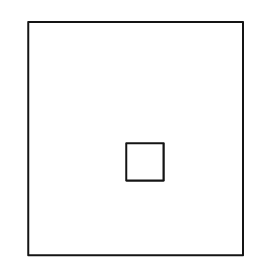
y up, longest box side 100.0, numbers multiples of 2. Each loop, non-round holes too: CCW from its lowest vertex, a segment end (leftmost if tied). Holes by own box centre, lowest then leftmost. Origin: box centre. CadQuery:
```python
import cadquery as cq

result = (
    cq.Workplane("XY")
    .moveTo(-46.0, -50.0)
    .lineTo(46.0, -50.0)
    .lineTo(46.0, 50.0)
    .lineTo(-46.0, 50.0)
    .close()
    .moveTo(-4.0, -18.0)
    .lineTo(12.0, -18.0)
    .lineTo(12.0, -2.0)
    .lineTo(-4.0, -2.0)
    .close()
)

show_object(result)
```